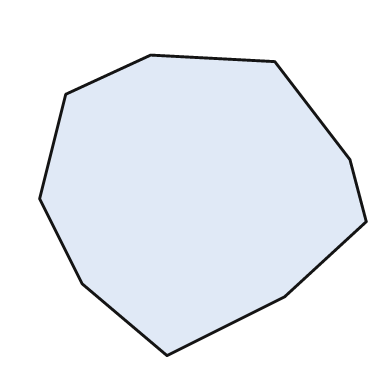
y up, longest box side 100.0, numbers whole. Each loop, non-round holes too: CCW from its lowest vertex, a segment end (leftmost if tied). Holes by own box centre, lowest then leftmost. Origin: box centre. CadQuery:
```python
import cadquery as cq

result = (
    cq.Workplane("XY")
    .moveTo(-11.0, -46.0)
    .lineTo(25.0, -28.0)
    .lineTo(50.0, -5.0)
    .lineTo(45.0, 14.0)
    .lineTo(22.0, 44.0)
    .lineTo(-16.0, 46.0)
    .lineTo(-42.0, 34.0)
    .lineTo(-50.0, 2.0)
    .lineTo(-37.0, -24.0)
    .close()
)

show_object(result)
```